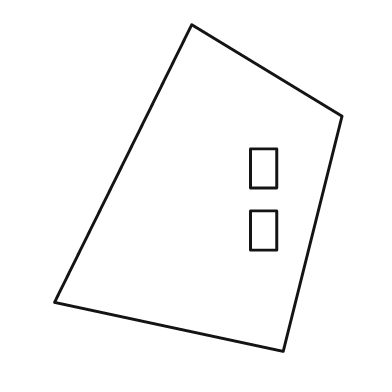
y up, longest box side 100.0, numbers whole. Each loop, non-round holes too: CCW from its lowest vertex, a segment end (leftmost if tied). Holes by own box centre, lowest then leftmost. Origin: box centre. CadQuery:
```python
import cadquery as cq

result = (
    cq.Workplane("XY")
    .moveTo(26.0, -50.0)
    .lineTo(44.0, 22.0)
    .lineTo(-2.0, 50.0)
    .lineTo(-44.0, -35.0)
    .close()
    .moveTo(16.0, -19.0)
    .lineTo(24.0, -19.0)
    .lineTo(24.0, -7.0)
    .lineTo(16.0, -7.0)
    .close()
    .moveTo(16.0, 0.0)
    .lineTo(24.0, 0.0)
    .lineTo(24.0, 12.0)
    .lineTo(16.0, 12.0)
    .close()
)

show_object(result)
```